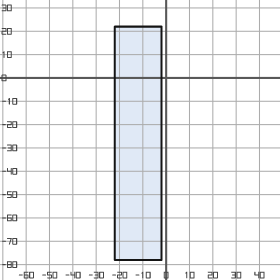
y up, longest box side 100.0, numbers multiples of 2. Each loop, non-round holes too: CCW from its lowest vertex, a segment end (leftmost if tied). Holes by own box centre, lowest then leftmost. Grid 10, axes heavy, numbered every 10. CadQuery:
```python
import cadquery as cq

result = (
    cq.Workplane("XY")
    .moveTo(-22.0, -78.0)
    .lineTo(-2.0, -78.0)
    .lineTo(-2.0, 22.0)
    .lineTo(-22.0, 22.0)
    .close()
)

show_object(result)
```